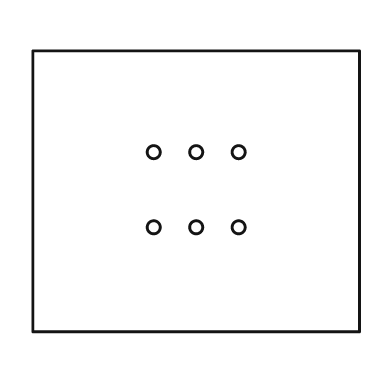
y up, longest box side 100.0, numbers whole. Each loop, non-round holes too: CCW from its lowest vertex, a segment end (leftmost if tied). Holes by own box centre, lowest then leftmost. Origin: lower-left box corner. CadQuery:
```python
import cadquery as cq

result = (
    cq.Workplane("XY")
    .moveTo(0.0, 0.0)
    .lineTo(100.0, 0.0)
    .lineTo(100.0, 86.0)
    .lineTo(0.0, 86.0)
    .close()
    .moveTo(37.0, 32.0)
    .circle(2.0)
    .moveTo(50.0, 32.0)
    .circle(2.0)
    .moveTo(63.0, 32.0)
    .circle(2.0)
    .moveTo(37.0, 55.0)
    .circle(2.0)
    .moveTo(50.0, 55.0)
    .circle(2.0)
    .moveTo(63.0, 55.0)
    .circle(2.0)
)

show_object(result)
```